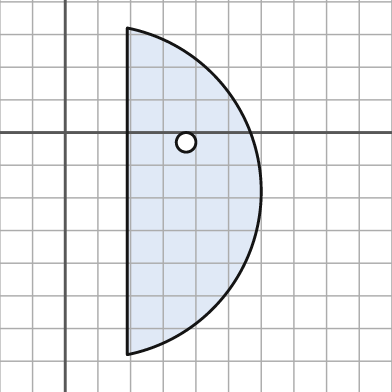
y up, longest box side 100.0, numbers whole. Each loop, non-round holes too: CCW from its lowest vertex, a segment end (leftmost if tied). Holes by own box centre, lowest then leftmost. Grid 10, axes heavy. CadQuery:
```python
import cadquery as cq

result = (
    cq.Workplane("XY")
    .moveTo(19.0, -68.0)
    .threePointArc((60.0, -18.0), (19.0, 32.0))
    .close()
    .moveTo(37.0, -3.0)
    .circle(3.0)
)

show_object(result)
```